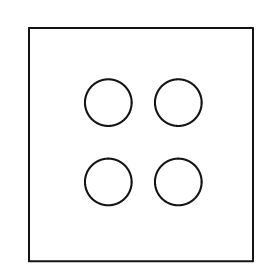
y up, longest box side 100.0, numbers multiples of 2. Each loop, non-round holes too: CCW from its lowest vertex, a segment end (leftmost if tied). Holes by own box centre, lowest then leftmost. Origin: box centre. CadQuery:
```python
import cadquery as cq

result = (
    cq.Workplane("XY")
    .moveTo(-48.0, -50.0)
    .lineTo(48.0, -50.0)
    .lineTo(48.0, 50.0)
    .lineTo(-48.0, 50.0)
    .close()
    .moveTo(-14.0, -16.0)
    .circle(10.0)
    .moveTo(16.0, -16.0)
    .circle(10.0)
    .moveTo(-14.0, 18.0)
    .circle(10.0)
    .moveTo(16.0, 18.0)
    .circle(10.0)
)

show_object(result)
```